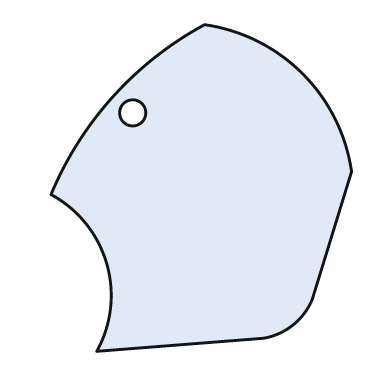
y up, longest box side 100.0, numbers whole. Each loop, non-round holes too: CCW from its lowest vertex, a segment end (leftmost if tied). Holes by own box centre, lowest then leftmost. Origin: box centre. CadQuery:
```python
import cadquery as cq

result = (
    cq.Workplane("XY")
    .moveTo(-32.0, -50.0)
    .lineTo(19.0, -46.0)
    .threePointArc((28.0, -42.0), (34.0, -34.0))
    .lineTo(46.0, 5.0)
    .threePointArc((31.0, 35.0), (1.0, 50.0))
    .threePointArc((-27.0, 28.0), (-46.0, -2.0))
    .threePointArc((-29.0, -23.0), (-32.0, -50.0))
    .close()
    .moveTo(-21.0, 23.0)
    .circle(4.0)
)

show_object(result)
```